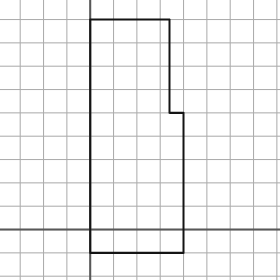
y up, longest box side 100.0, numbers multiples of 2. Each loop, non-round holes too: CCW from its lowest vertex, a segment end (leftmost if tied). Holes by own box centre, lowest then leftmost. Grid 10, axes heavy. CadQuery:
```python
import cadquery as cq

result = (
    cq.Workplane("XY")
    .moveTo(0.0, -10.0)
    .lineTo(40.0, -10.0)
    .lineTo(40.0, 50.0)
    .lineTo(34.0, 50.0)
    .lineTo(34.0, 90.0)
    .lineTo(0.0, 90.0)
    .close()
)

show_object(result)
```